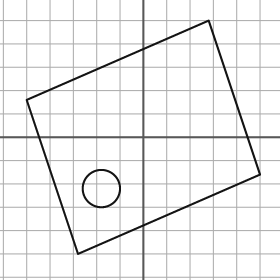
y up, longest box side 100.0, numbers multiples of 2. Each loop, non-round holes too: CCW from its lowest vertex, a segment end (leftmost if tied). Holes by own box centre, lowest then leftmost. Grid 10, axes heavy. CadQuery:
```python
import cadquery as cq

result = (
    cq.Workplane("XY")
    .moveTo(-28.0, -50.0)
    .lineTo(50.0, -16.0)
    .lineTo(28.0, 50.0)
    .lineTo(-50.0, 16.0)
    .close()
    .moveTo(-18.0, -22.0)
    .circle(8.0)
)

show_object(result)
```